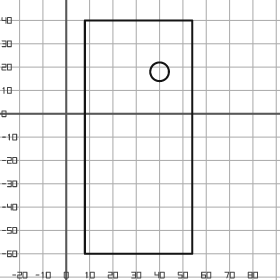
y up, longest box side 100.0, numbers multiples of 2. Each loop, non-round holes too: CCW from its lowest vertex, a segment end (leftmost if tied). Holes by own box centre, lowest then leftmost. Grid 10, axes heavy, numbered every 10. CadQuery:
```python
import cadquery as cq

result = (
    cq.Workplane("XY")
    .moveTo(8.0, -60.0)
    .lineTo(54.0, -60.0)
    .lineTo(54.0, 40.0)
    .lineTo(8.0, 40.0)
    .close()
    .moveTo(40.0, 18.0)
    .circle(4.0)
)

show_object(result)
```